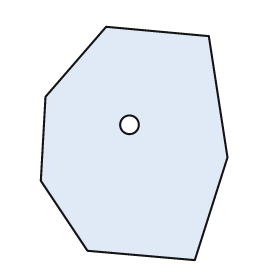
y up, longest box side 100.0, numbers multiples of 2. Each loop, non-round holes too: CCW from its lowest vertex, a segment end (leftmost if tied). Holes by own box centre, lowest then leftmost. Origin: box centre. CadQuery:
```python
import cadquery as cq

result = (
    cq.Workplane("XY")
    .moveTo(26.0, -50.0)
    .lineTo(40.0, -6.0)
    .lineTo(32.0, 46.0)
    .lineTo(-12.0, 50.0)
    .lineTo(-38.0, 20.0)
    .lineTo(-40.0, -16.0)
    .lineTo(-20.0, -46.0)
    .close()
    .moveTo(-2.0, 8.0)
    .circle(4.0)
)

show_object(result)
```